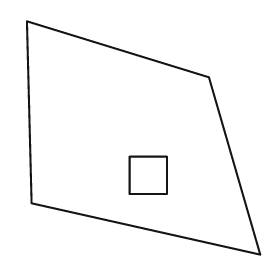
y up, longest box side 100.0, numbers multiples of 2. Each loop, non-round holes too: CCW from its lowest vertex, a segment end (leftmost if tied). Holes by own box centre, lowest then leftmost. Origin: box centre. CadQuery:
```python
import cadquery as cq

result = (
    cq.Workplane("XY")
    .moveTo(50.0, -50.0)
    .lineTo(28.0, 26.0)
    .lineTo(-50.0, 50.0)
    .lineTo(-48.0, -28.0)
    .close()
    .moveTo(-6.0, -24.0)
    .lineTo(10.0, -24.0)
    .lineTo(10.0, -8.0)
    .lineTo(-6.0, -8.0)
    .close()
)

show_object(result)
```